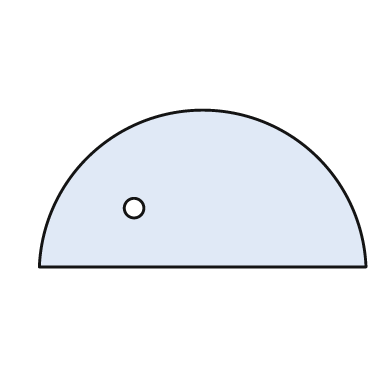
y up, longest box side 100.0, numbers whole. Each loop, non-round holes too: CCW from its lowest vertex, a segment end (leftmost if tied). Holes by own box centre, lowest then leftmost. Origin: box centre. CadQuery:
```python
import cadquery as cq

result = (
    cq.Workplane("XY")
    .moveTo(-50.0, -24.0)
    .lineTo(50.0, -24.0)
    .threePointArc((0.0, 24.0), (-50.0, -24.0))
    .close()
    .moveTo(-21.0, -6.0)
    .circle(3.0)
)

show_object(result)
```